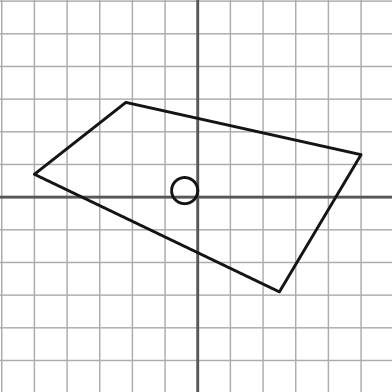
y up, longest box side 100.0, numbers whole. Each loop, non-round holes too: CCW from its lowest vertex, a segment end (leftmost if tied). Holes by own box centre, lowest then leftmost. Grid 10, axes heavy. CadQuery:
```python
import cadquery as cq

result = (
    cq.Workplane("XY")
    .moveTo(25.0, -29.0)
    .lineTo(50.0, 13.0)
    .lineTo(-22.0, 29.0)
    .lineTo(-50.0, 7.0)
    .close()
    .moveTo(-4.0, 2.0)
    .circle(4.0)
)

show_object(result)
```